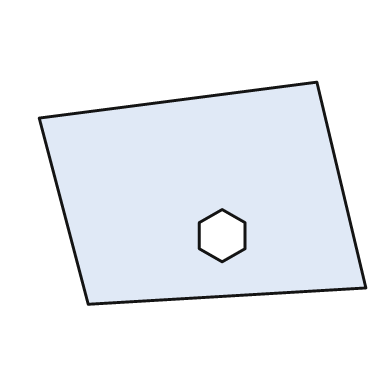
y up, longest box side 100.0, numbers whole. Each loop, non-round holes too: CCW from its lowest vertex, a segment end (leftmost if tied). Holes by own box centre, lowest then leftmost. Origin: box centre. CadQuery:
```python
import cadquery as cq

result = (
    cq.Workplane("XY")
    .moveTo(-35.0, -34.0)
    .lineTo(50.0, -29.0)
    .lineTo(35.0, 34.0)
    .lineTo(-50.0, 23.0)
    .close()
    .moveTo(6.0, -21.0)
    .lineTo(13.0, -17.0)
    .lineTo(13.0, -9.0)
    .lineTo(6.0, -5.0)
    .lineTo(-1.0, -9.0)
    .lineTo(-1.0, -17.0)
    .close()
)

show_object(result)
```